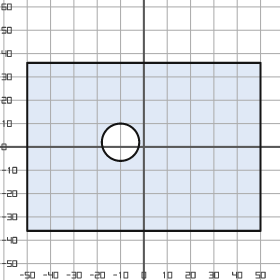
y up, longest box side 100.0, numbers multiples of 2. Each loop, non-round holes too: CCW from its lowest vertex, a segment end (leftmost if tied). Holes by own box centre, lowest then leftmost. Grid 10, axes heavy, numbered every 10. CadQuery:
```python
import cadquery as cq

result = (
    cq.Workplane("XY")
    .moveTo(-50.0, -36.0)
    .lineTo(50.0, -36.0)
    .lineTo(50.0, 36.0)
    .lineTo(-50.0, 36.0)
    .close()
    .moveTo(-10.0, 2.0)
    .circle(8.0)
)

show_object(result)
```